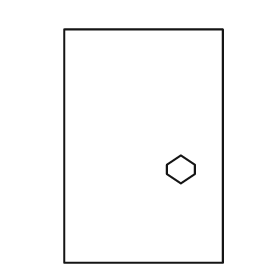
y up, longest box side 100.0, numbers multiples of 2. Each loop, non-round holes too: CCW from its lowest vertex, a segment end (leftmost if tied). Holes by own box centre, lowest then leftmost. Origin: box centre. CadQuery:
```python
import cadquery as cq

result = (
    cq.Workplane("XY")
    .moveTo(-34.0, -50.0)
    .lineTo(34.0, -50.0)
    .lineTo(34.0, 50.0)
    .lineTo(-34.0, 50.0)
    .close()
    .moveTo(16.0, -16.0)
    .lineTo(22.0, -12.0)
    .lineTo(22.0, -8.0)
    .lineTo(16.0, -4.0)
    .lineTo(10.0, -8.0)
    .lineTo(10.0, -12.0)
    .close()
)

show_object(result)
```